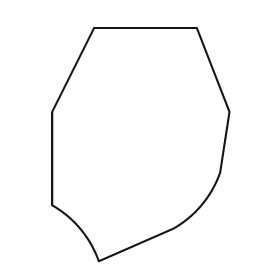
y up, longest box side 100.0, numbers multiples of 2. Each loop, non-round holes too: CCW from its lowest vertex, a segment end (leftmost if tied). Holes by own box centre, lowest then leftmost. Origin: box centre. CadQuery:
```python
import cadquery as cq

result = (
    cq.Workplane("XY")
    .moveTo(-18.0, -50.0)
    .lineTo(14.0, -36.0)
    .threePointArc((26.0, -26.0), (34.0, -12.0))
    .lineTo(38.0, 14.0)
    .lineTo(24.0, 50.0)
    .lineTo(-20.0, 50.0)
    .lineTo(-38.0, 14.0)
    .lineTo(-38.0, -26.0)
    .threePointArc((-26.0, -36.0), (-18.0, -50.0))
    .close()
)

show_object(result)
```